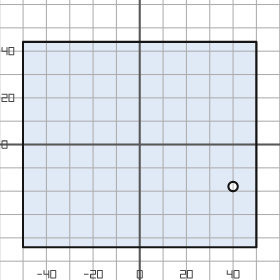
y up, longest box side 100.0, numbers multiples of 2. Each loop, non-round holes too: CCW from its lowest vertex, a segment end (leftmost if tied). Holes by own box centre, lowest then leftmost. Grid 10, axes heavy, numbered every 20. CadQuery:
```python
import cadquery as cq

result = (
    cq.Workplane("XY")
    .moveTo(-50.0, -44.0)
    .lineTo(50.0, -44.0)
    .lineTo(50.0, 44.0)
    .lineTo(-50.0, 44.0)
    .close()
    .moveTo(40.0, -18.0)
    .circle(2.0)
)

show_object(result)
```